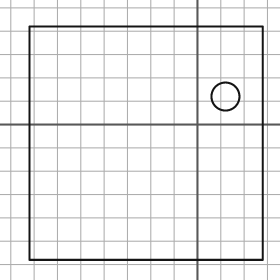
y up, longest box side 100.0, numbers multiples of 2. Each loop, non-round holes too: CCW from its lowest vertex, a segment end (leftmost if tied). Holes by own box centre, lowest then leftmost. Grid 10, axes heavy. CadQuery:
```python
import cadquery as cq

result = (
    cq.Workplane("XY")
    .moveTo(-72.0, -58.0)
    .lineTo(28.0, -58.0)
    .lineTo(28.0, 42.0)
    .lineTo(-72.0, 42.0)
    .close()
    .moveTo(12.0, 12.0)
    .circle(6.0)
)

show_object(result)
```